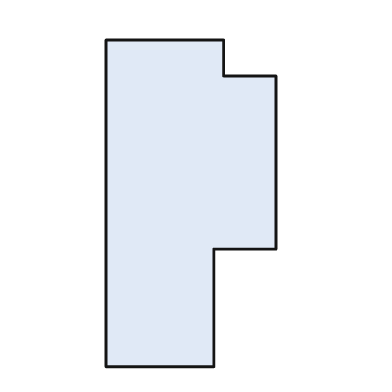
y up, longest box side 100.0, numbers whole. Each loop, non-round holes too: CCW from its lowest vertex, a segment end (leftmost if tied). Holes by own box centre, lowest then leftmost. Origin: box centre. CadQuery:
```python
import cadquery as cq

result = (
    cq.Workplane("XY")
    .moveTo(-26.0, -50.0)
    .lineTo(7.0, -50.0)
    .lineTo(7.0, -14.0)
    .lineTo(26.0, -14.0)
    .lineTo(26.0, 39.0)
    .lineTo(10.0, 39.0)
    .lineTo(10.0, 50.0)
    .lineTo(-26.0, 50.0)
    .close()
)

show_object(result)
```